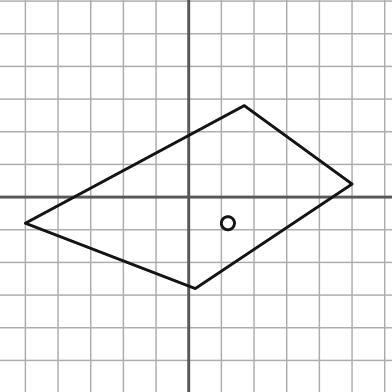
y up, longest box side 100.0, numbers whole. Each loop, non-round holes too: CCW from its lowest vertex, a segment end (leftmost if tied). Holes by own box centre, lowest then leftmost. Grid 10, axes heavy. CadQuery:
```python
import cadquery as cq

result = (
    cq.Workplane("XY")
    .moveTo(2.0, -28.0)
    .lineTo(50.0, 4.0)
    .lineTo(17.0, 28.0)
    .lineTo(-50.0, -8.0)
    .close()
    .moveTo(12.0, -8.0)
    .circle(2.0)
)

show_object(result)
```